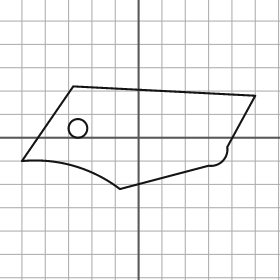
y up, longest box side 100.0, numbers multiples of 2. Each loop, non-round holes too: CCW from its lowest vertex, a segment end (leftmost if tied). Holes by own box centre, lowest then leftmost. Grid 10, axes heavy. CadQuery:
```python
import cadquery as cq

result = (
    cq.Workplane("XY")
    .moveTo(-8.0, -22.0)
    .lineTo(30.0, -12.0)
    .threePointArc((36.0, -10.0), (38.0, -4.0))
    .lineTo(50.0, 18.0)
    .lineTo(-28.0, 22.0)
    .lineTo(-50.0, -10.0)
    .threePointArc((-28.0, -12.0), (-8.0, -22.0))
    .close()
    .moveTo(-26.0, 4.0)
    .circle(4.0)
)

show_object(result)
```